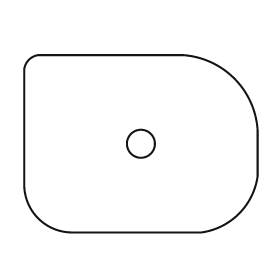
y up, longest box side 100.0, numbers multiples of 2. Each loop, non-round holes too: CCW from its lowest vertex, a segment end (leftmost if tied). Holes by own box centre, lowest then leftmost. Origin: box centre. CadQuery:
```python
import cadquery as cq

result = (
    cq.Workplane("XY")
    .moveTo(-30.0, -38.0)
    .lineTo(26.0, -38.0)
    .threePointArc((42.0, -30.0), (50.0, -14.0))
    .lineTo(50.0, 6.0)
    .threePointArc((40.0, 28.0), (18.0, 38.0))
    .lineTo(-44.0, 38.0)
    .threePointArc((-48.0, 36.0), (-50.0, 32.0))
    .lineTo(-50.0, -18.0)
    .threePointArc((-44.0, -32.0), (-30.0, -38.0))
    .close()
    .moveTo(0.0, 0.0)
    .circle(6.0)
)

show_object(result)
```